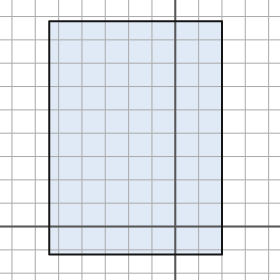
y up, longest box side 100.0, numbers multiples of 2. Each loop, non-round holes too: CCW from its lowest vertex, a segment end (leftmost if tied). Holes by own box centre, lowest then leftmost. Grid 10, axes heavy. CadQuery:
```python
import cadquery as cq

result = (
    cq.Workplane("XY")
    .moveTo(-54.0, -12.0)
    .lineTo(20.0, -12.0)
    .lineTo(20.0, 88.0)
    .lineTo(-54.0, 88.0)
    .close()
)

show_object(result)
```